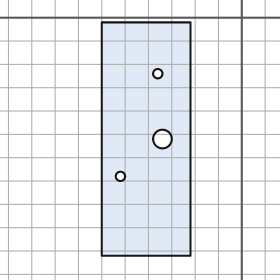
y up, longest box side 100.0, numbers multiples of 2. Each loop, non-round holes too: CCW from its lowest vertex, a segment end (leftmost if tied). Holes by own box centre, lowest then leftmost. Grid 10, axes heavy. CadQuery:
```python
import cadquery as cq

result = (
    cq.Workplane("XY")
    .moveTo(-60.0, -102.0)
    .lineTo(-22.0, -102.0)
    .lineTo(-22.0, -2.0)
    .lineTo(-60.0, -2.0)
    .close()
    .moveTo(-52.0, -68.0)
    .circle(2.0)
    .moveTo(-34.0, -52.0)
    .circle(4.0)
    .moveTo(-36.0, -24.0)
    .circle(2.0)
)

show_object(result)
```